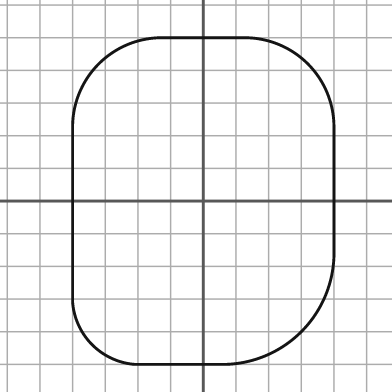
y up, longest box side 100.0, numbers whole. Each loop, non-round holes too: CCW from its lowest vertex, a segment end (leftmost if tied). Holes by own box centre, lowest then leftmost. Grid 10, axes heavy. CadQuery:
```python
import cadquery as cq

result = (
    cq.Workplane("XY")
    .moveTo(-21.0, -50.0)
    .lineTo(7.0, -50.0)
    .threePointArc((30.0, -40.0), (40.0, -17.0))
    .lineTo(40.0, 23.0)
    .threePointArc((32.0, 42.0), (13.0, 50.0))
    .lineTo(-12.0, 50.0)
    .threePointArc((-32.0, 42.0), (-40.0, 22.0))
    .lineTo(-40.0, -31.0)
    .threePointArc((-34.0, -44.0), (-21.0, -50.0))
    .close()
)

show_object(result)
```